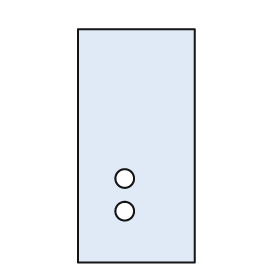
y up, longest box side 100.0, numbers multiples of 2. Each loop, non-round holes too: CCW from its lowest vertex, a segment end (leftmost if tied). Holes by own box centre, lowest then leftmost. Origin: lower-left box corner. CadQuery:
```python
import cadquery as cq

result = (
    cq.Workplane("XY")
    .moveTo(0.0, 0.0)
    .lineTo(50.0, 0.0)
    .lineTo(50.0, 100.0)
    .lineTo(0.0, 100.0)
    .close()
    .moveTo(20.0, 22.0)
    .circle(4.0)
    .moveTo(20.0, 36.0)
    .circle(4.0)
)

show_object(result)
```